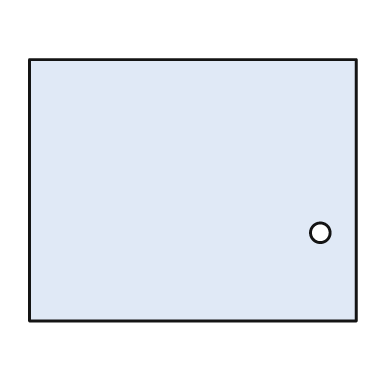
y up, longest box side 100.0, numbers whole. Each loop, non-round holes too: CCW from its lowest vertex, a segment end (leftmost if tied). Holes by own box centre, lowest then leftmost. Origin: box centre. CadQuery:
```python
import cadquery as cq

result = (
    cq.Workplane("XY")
    .moveTo(-50.0, -40.0)
    .lineTo(50.0, -40.0)
    .lineTo(50.0, 40.0)
    .lineTo(-50.0, 40.0)
    .close()
    .moveTo(39.0, -13.0)
    .circle(3.0)
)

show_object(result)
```